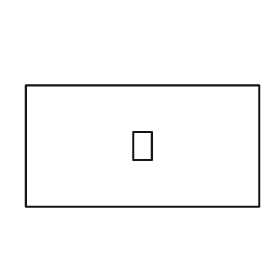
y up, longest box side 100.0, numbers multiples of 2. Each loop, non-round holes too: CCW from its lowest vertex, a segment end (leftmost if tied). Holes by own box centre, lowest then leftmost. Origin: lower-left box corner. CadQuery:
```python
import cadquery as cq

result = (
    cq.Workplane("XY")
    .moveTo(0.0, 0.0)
    .lineTo(100.0, 0.0)
    .lineTo(100.0, 52.0)
    .lineTo(0.0, 52.0)
    .close()
    .moveTo(46.0, 20.0)
    .lineTo(54.0, 20.0)
    .lineTo(54.0, 32.0)
    .lineTo(46.0, 32.0)
    .close()
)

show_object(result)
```